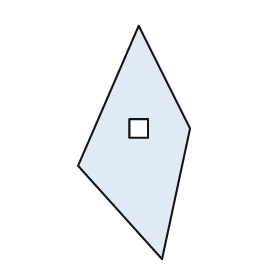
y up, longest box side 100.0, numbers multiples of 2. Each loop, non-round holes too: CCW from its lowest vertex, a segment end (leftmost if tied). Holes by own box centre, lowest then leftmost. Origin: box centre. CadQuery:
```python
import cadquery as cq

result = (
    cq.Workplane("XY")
    .moveTo(12.0, -50.0)
    .lineTo(24.0, 6.0)
    .lineTo(2.0, 50.0)
    .lineTo(-24.0, -10.0)
    .close()
    .moveTo(-2.0, 2.0)
    .lineTo(6.0, 2.0)
    .lineTo(6.0, 10.0)
    .lineTo(-2.0, 10.0)
    .close()
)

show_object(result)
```